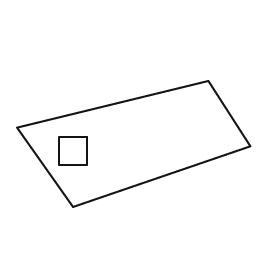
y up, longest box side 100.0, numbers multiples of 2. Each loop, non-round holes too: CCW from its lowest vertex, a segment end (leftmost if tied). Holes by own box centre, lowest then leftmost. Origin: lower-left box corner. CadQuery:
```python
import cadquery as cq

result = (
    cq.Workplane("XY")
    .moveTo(24.0, 0.0)
    .lineTo(100.0, 26.0)
    .lineTo(82.0, 54.0)
    .lineTo(0.0, 34.0)
    .close()
    .moveTo(18.0, 18.0)
    .lineTo(30.0, 18.0)
    .lineTo(30.0, 30.0)
    .lineTo(18.0, 30.0)
    .close()
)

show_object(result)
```